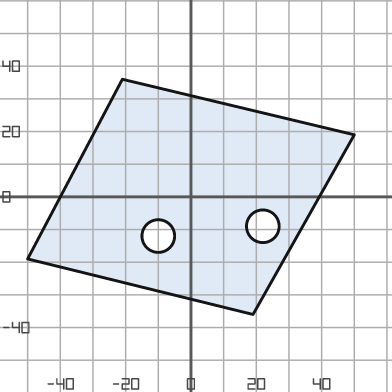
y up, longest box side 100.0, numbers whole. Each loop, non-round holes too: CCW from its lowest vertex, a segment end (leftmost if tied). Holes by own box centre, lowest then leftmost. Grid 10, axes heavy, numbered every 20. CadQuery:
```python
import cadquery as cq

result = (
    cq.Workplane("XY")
    .moveTo(19.0, -36.0)
    .lineTo(50.0, 19.0)
    .lineTo(-21.0, 36.0)
    .lineTo(-50.0, -19.0)
    .close()
    .moveTo(-10.0, -12.0)
    .circle(5.0)
    .moveTo(22.0, -9.0)
    .circle(5.0)
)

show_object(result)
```